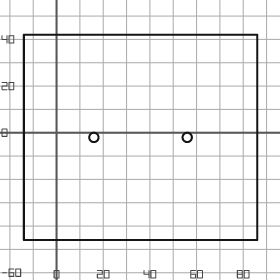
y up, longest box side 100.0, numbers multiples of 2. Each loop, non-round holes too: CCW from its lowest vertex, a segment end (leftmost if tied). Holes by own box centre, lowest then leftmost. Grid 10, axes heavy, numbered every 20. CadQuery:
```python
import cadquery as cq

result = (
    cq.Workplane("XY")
    .moveTo(-14.0, -46.0)
    .lineTo(86.0, -46.0)
    .lineTo(86.0, 42.0)
    .lineTo(-14.0, 42.0)
    .close()
    .moveTo(16.0, -2.0)
    .circle(2.0)
    .moveTo(56.0, -2.0)
    .circle(2.0)
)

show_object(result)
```